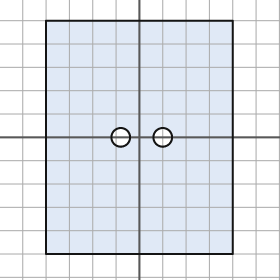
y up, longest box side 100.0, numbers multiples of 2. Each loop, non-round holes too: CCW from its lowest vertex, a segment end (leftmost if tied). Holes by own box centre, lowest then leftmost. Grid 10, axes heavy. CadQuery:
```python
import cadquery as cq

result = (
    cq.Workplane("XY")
    .moveTo(-40.0, -50.0)
    .lineTo(40.0, -50.0)
    .lineTo(40.0, 50.0)
    .lineTo(-40.0, 50.0)
    .close()
    .moveTo(-8.0, 0.0)
    .circle(4.0)
    .moveTo(10.0, 0.0)
    .circle(4.0)
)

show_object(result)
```